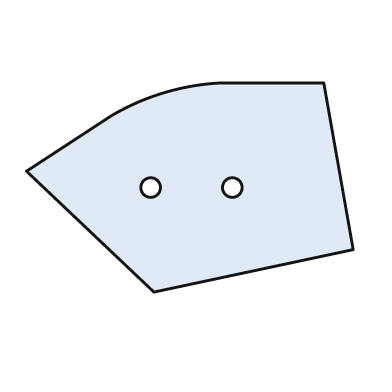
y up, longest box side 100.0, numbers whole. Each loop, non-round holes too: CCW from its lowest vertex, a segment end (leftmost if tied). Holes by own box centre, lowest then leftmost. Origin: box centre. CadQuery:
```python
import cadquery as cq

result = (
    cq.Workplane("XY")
    .moveTo(-11.0, -32.0)
    .lineTo(50.0, -19.0)
    .lineTo(41.0, 32.0)
    .lineTo(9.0, 32.0)
    .threePointArc((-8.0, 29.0), (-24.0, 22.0))
    .lineTo(-50.0, 5.0)
    .close()
    .moveTo(-12.0, 0.0)
    .circle(3.0)
    .moveTo(13.0, 0.0)
    .circle(3.0)
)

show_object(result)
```